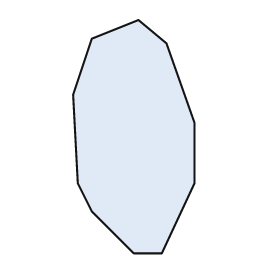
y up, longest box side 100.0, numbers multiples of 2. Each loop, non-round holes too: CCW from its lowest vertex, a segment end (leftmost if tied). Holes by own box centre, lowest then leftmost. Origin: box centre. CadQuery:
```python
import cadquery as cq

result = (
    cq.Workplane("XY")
    .moveTo(0.0, -50.0)
    .lineTo(12.0, -50.0)
    .lineTo(26.0, -20.0)
    .lineTo(26.0, 6.0)
    .lineTo(14.0, 40.0)
    .lineTo(2.0, 50.0)
    .lineTo(-18.0, 42.0)
    .lineTo(-26.0, 18.0)
    .lineTo(-24.0, -20.0)
    .lineTo(-18.0, -32.0)
    .close()
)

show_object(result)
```